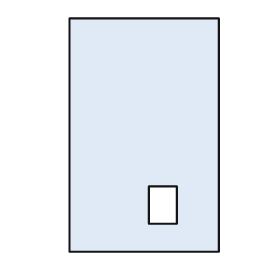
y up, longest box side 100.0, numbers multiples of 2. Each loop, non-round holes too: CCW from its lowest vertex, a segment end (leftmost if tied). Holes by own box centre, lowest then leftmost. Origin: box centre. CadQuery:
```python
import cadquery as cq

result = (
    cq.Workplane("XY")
    .moveTo(-32.0, -50.0)
    .lineTo(32.0, -50.0)
    .lineTo(32.0, 50.0)
    .lineTo(-32.0, 50.0)
    .close()
    .moveTo(2.0, -38.0)
    .lineTo(14.0, -38.0)
    .lineTo(14.0, -22.0)
    .lineTo(2.0, -22.0)
    .close()
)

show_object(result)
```